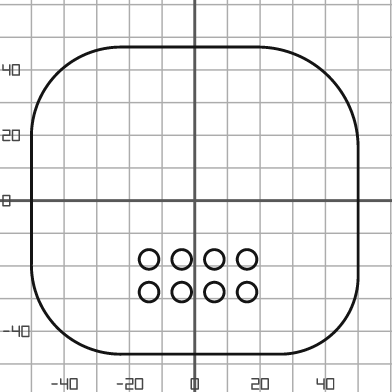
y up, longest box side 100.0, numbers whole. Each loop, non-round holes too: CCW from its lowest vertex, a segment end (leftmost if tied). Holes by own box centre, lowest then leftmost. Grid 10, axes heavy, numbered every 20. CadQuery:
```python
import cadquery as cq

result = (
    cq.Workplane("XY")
    .moveTo(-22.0, -47.0)
    .lineTo(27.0, -47.0)
    .threePointArc((43.0, -40.0), (50.0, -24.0))
    .lineTo(50.0, 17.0)
    .threePointArc((41.0, 38.0), (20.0, 47.0))
    .lineTo(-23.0, 47.0)
    .threePointArc((-42.0, 39.0), (-50.0, 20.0))
    .lineTo(-50.0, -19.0)
    .threePointArc((-42.0, -39.0), (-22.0, -47.0))
    .close()
    .moveTo(-14.0, -28.0)
    .circle(3.0)
    .moveTo(-4.0, -28.0)
    .circle(3.0)
    .moveTo(6.0, -28.0)
    .circle(3.0)
    .moveTo(16.0, -28.0)
    .circle(3.0)
    .moveTo(-14.0, -18.0)
    .circle(3.0)
    .moveTo(-4.0, -18.0)
    .circle(3.0)
    .moveTo(6.0, -18.0)
    .circle(3.0)
    .moveTo(16.0, -18.0)
    .circle(3.0)
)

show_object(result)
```